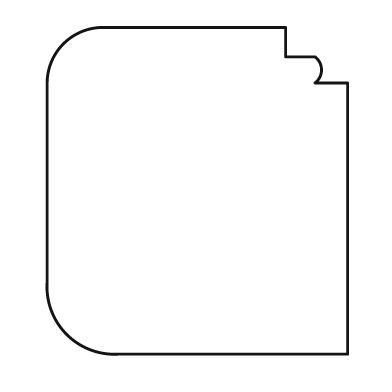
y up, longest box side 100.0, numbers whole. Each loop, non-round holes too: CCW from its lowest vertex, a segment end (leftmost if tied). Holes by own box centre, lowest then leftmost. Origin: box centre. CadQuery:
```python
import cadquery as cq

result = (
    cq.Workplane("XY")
    .moveTo(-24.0, -50.0)
    .lineTo(46.0, -50.0)
    .lineTo(46.0, 33.0)
    .lineTo(36.0, 33.0)
    .threePointArc((38.0, 37.0), (36.0, 41.0))
    .lineTo(27.0, 41.0)
    .lineTo(27.0, 50.0)
    .lineTo(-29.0, 50.0)
    .threePointArc((-41.0, 45.0), (-46.0, 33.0))
    .lineTo(-46.0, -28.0)
    .threePointArc((-40.0, -44.0), (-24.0, -50.0))
    .close()
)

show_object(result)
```